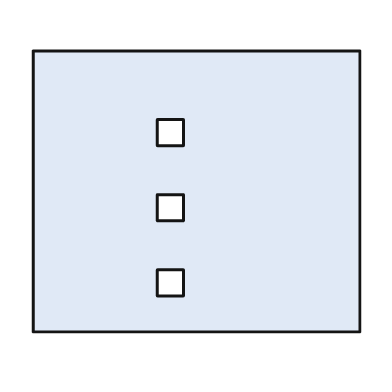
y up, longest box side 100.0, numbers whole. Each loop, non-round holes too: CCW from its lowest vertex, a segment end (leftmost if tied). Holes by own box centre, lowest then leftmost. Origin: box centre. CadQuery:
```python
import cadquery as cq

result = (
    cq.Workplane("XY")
    .moveTo(-50.0, -43.0)
    .lineTo(50.0, -43.0)
    .lineTo(50.0, 43.0)
    .lineTo(-50.0, 43.0)
    .close()
    .moveTo(-12.0, -32.0)
    .lineTo(-4.0, -32.0)
    .lineTo(-4.0, -24.0)
    .lineTo(-12.0, -24.0)
    .close()
    .moveTo(-12.0, -9.0)
    .lineTo(-4.0, -9.0)
    .lineTo(-4.0, -1.0)
    .lineTo(-12.0, -1.0)
    .close()
    .moveTo(-12.0, 14.0)
    .lineTo(-4.0, 14.0)
    .lineTo(-4.0, 22.0)
    .lineTo(-12.0, 22.0)
    .close()
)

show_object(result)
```